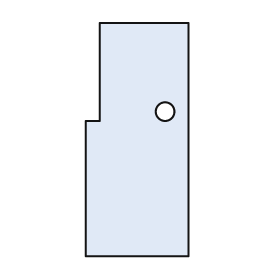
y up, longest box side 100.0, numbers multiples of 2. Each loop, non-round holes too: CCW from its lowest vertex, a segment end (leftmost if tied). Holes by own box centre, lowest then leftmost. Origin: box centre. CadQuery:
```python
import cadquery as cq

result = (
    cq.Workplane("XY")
    .moveTo(-22.0, -50.0)
    .lineTo(22.0, -50.0)
    .lineTo(22.0, 50.0)
    .lineTo(-16.0, 50.0)
    .lineTo(-16.0, 8.0)
    .lineTo(-22.0, 8.0)
    .close()
    .moveTo(12.0, 12.0)
    .circle(4.0)
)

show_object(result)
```